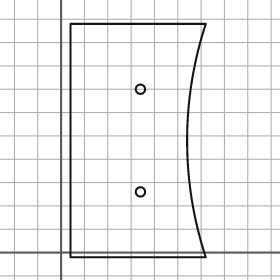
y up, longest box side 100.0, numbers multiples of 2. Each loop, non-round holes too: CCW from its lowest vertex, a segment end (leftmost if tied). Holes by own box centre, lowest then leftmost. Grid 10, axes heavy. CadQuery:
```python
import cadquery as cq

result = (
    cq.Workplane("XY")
    .moveTo(4.0, -2.0)
    .lineTo(62.0, -2.0)
    .threePointArc((54.0, 48.0), (62.0, 98.0))
    .lineTo(4.0, 98.0)
    .close()
    .moveTo(34.0, 26.0)
    .circle(2.0)
    .moveTo(34.0, 70.0)
    .circle(2.0)
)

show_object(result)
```